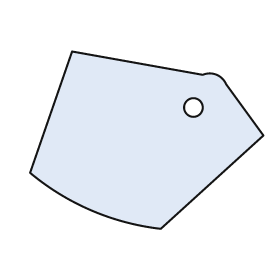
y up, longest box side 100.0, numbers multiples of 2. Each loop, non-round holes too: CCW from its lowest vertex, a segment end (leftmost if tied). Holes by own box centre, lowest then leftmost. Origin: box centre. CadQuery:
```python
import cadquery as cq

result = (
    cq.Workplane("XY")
    .moveTo(6.0, -38.0)
    .lineTo(50.0, 2.0)
    .lineTo(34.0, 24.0)
    .threePointArc((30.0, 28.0), (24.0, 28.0))
    .lineTo(-32.0, 38.0)
    .lineTo(-50.0, -14.0)
    .threePointArc((-24.0, -30.0), (6.0, -38.0))
    .close()
    .moveTo(20.0, 14.0)
    .circle(4.0)
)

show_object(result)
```